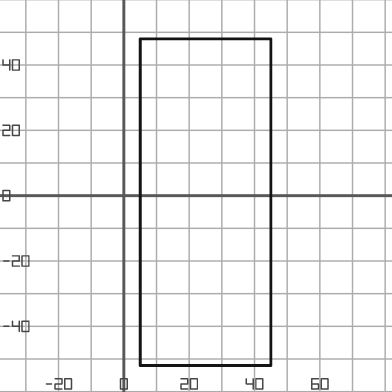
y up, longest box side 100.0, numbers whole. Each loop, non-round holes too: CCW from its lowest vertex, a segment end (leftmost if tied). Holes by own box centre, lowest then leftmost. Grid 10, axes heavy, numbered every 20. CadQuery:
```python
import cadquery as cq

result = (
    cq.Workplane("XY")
    .moveTo(5.0, -52.0)
    .lineTo(45.0, -52.0)
    .lineTo(45.0, 48.0)
    .lineTo(5.0, 48.0)
    .close()
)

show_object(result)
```